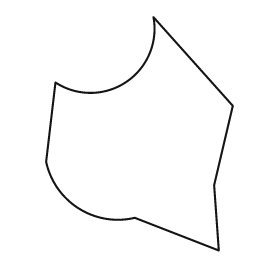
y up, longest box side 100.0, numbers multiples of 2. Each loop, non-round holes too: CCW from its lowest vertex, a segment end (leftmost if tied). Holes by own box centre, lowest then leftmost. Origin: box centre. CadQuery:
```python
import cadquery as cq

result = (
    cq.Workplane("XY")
    .moveTo(34.0, -50.0)
    .lineTo(32.0, -22.0)
    .lineTo(40.0, 12.0)
    .lineTo(6.0, 50.0)
    .threePointArc((-6.0, 22.0), (-36.0, 22.0))
    .lineTo(-40.0, -12.0)
    .threePointArc((-26.0, -32.0), (-2.0, -36.0))
    .close()
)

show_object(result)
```